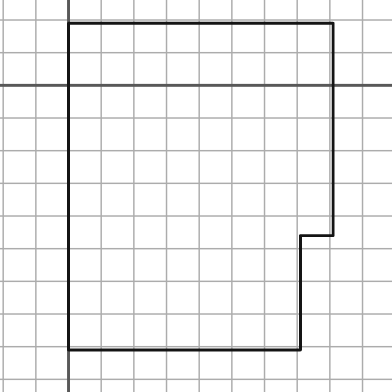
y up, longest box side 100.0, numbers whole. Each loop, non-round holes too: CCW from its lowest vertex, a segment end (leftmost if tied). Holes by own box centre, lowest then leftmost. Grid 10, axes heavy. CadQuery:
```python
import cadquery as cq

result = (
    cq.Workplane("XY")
    .moveTo(0.0, -81.0)
    .lineTo(71.0, -81.0)
    .lineTo(71.0, -46.0)
    .lineTo(81.0, -46.0)
    .lineTo(81.0, 19.0)
    .lineTo(0.0, 19.0)
    .close()
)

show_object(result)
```